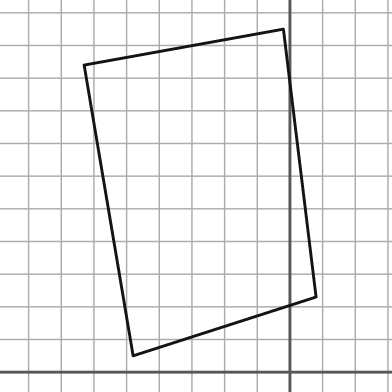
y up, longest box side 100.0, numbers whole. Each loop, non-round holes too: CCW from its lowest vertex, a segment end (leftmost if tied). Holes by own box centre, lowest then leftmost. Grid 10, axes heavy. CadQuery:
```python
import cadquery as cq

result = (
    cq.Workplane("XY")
    .moveTo(-48.0, 5.0)
    .lineTo(8.0, 23.0)
    .lineTo(-2.0, 105.0)
    .lineTo(-63.0, 94.0)
    .close()
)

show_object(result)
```